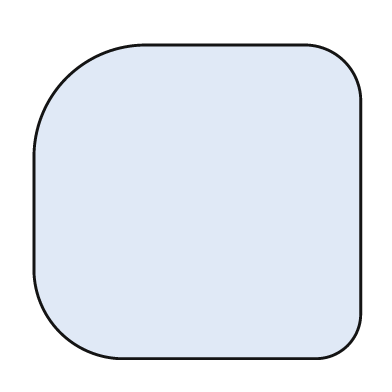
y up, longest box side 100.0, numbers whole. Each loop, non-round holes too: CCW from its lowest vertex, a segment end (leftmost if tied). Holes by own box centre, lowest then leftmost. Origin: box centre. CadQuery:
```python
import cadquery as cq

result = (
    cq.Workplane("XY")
    .moveTo(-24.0, -48.0)
    .lineTo(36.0, -48.0)
    .threePointArc((46.0, -44.0), (50.0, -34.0))
    .lineTo(50.0, 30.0)
    .threePointArc((45.0, 43.0), (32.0, 48.0))
    .lineTo(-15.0, 48.0)
    .threePointArc((-40.0, 38.0), (-50.0, 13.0))
    .lineTo(-50.0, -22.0)
    .threePointArc((-42.0, -40.0), (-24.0, -48.0))
    .close()
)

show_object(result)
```